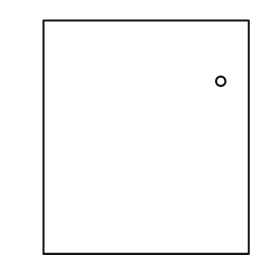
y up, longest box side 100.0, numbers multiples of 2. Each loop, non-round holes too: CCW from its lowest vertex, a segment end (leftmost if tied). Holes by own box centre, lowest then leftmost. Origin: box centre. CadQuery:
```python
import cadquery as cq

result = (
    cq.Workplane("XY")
    .moveTo(-44.0, -50.0)
    .lineTo(44.0, -50.0)
    .lineTo(44.0, 50.0)
    .lineTo(-44.0, 50.0)
    .close()
    .moveTo(32.0, 24.0)
    .circle(2.0)
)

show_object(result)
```